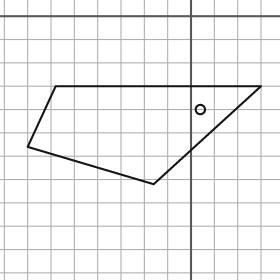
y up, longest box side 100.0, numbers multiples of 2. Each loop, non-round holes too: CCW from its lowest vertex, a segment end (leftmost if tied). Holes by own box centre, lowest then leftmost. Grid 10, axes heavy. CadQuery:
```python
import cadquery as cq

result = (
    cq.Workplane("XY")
    .moveTo(-16.0, -72.0)
    .lineTo(30.0, -30.0)
    .lineTo(-58.0, -30.0)
    .lineTo(-70.0, -56.0)
    .close()
    .moveTo(4.0, -40.0)
    .circle(2.0)
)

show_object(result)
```